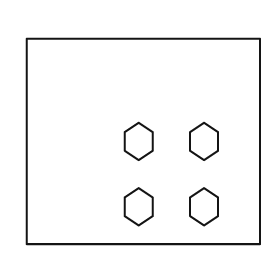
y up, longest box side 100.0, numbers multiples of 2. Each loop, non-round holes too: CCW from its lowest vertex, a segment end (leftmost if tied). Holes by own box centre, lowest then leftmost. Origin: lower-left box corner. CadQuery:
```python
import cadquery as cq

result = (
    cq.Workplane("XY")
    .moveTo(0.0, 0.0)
    .lineTo(100.0, 0.0)
    .lineTo(100.0, 88.0)
    .lineTo(0.0, 88.0)
    .close()
    .moveTo(48.0, 8.0)
    .lineTo(54.0, 12.0)
    .lineTo(54.0, 20.0)
    .lineTo(48.0, 24.0)
    .lineTo(42.0, 20.0)
    .lineTo(42.0, 12.0)
    .close()
    .moveTo(76.0, 8.0)
    .lineTo(82.0, 12.0)
    .lineTo(82.0, 20.0)
    .lineTo(76.0, 24.0)
    .lineTo(70.0, 20.0)
    .lineTo(70.0, 12.0)
    .close()
    .moveTo(48.0, 36.0)
    .lineTo(54.0, 40.0)
    .lineTo(54.0, 48.0)
    .lineTo(48.0, 52.0)
    .lineTo(42.0, 48.0)
    .lineTo(42.0, 40.0)
    .close()
    .moveTo(76.0, 36.0)
    .lineTo(82.0, 40.0)
    .lineTo(82.0, 48.0)
    .lineTo(76.0, 52.0)
    .lineTo(70.0, 48.0)
    .lineTo(70.0, 40.0)
    .close()
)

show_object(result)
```